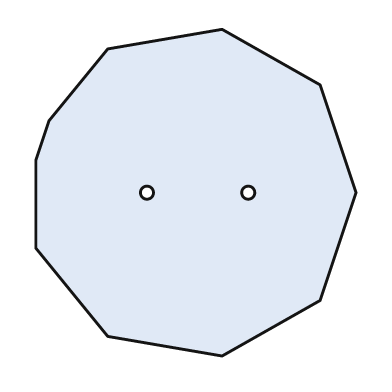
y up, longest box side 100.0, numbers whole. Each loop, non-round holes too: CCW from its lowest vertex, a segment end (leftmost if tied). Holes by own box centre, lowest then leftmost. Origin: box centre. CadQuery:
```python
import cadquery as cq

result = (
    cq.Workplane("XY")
    .moveTo(8.0, -50.0)
    .lineTo(38.0, -33.0)
    .lineTo(49.0, 0.0)
    .lineTo(38.0, 33.0)
    .lineTo(8.0, 50.0)
    .lineTo(-27.0, 44.0)
    .lineTo(-45.0, 22.0)
    .lineTo(-49.0, 10.0)
    .lineTo(-49.0, -17.0)
    .lineTo(-27.0, -44.0)
    .close()
    .moveTo(-15.0, 0.0)
    .circle(2.0)
    .moveTo(16.0, 0.0)
    .circle(2.0)
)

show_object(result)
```